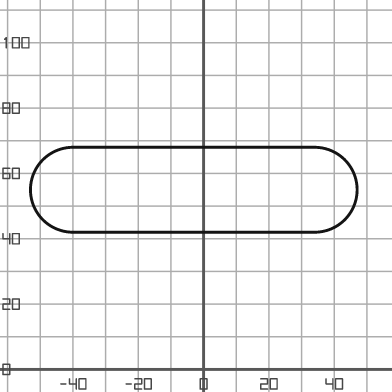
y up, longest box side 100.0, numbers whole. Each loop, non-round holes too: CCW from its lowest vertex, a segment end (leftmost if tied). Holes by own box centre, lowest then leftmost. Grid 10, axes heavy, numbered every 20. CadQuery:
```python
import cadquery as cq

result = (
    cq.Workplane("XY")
    .moveTo(-40.0, 42.0)
    .lineTo(34.0, 42.0)
    .threePointArc((47.0, 55.0), (34.0, 68.0))
    .lineTo(-40.0, 68.0)
    .threePointArc((-53.0, 55.0), (-40.0, 42.0))
    .close()
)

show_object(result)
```